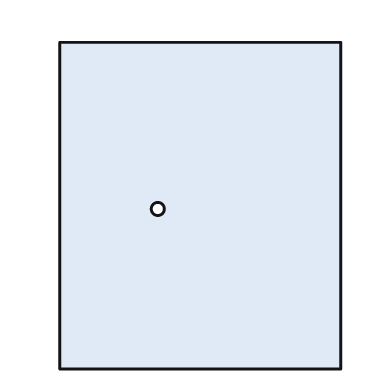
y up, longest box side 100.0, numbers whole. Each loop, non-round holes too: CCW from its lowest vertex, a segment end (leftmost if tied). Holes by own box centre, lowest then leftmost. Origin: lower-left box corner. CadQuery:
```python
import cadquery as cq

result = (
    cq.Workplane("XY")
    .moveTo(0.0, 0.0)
    .lineTo(86.0, 0.0)
    .lineTo(86.0, 100.0)
    .lineTo(0.0, 100.0)
    .close()
    .moveTo(30.0, 49.0)
    .circle(2.0)
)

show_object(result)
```